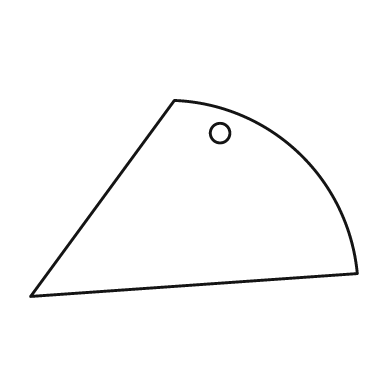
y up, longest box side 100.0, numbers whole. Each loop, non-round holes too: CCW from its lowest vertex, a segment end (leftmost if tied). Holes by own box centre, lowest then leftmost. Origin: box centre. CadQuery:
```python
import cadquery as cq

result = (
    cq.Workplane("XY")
    .moveTo(-50.0, -30.0)
    .lineTo(50.0, -23.0)
    .threePointArc((32.0, 14.0), (-6.0, 30.0))
    .close()
    .moveTo(8.0, 20.0)
    .circle(3.0)
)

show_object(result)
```